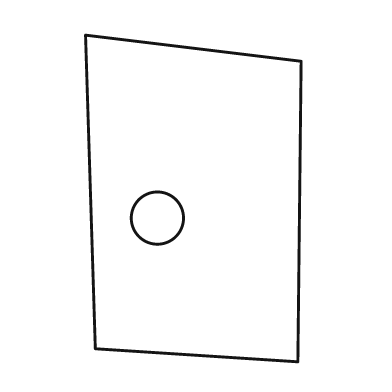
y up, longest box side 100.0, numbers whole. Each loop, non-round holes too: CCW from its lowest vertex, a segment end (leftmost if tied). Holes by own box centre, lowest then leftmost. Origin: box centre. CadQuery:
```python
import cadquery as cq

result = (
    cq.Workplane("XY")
    .moveTo(32.0, -50.0)
    .lineTo(33.0, 42.0)
    .lineTo(-33.0, 50.0)
    .lineTo(-30.0, -46.0)
    .close()
    .moveTo(-11.0, -6.0)
    .circle(8.0)
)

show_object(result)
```